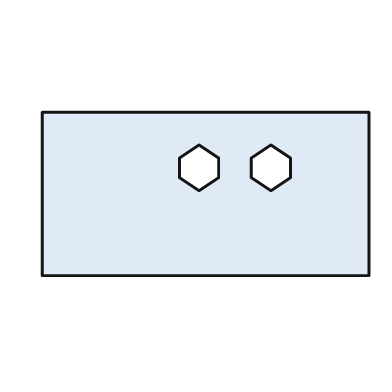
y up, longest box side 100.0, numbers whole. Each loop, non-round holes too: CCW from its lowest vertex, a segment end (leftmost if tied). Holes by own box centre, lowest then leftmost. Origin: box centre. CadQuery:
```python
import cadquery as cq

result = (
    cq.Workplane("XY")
    .moveTo(-50.0, -25.0)
    .lineTo(50.0, -25.0)
    .lineTo(50.0, 25.0)
    .lineTo(-50.0, 25.0)
    .close()
    .moveTo(-2.0, 1.0)
    .lineTo(4.0, 5.0)
    .lineTo(4.0, 11.0)
    .lineTo(-2.0, 15.0)
    .lineTo(-8.0, 11.0)
    .lineTo(-8.0, 5.0)
    .close()
    .moveTo(20.0, 1.0)
    .lineTo(26.0, 5.0)
    .lineTo(26.0, 11.0)
    .lineTo(20.0, 15.0)
    .lineTo(14.0, 11.0)
    .lineTo(14.0, 5.0)
    .close()
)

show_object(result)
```